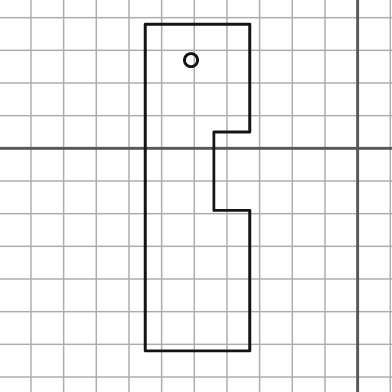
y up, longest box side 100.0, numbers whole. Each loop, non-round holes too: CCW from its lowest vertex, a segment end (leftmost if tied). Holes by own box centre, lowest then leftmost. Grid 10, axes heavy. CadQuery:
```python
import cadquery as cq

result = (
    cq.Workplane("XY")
    .moveTo(-65.0, -62.0)
    .lineTo(-33.0, -62.0)
    .lineTo(-33.0, -19.0)
    .lineTo(-44.0, -19.0)
    .lineTo(-44.0, 5.0)
    .lineTo(-33.0, 5.0)
    .lineTo(-33.0, 38.0)
    .lineTo(-65.0, 38.0)
    .close()
    .moveTo(-51.0, 27.0)
    .circle(2.0)
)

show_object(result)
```